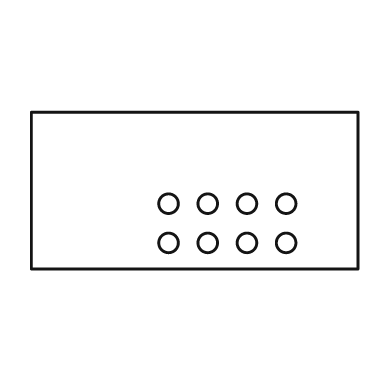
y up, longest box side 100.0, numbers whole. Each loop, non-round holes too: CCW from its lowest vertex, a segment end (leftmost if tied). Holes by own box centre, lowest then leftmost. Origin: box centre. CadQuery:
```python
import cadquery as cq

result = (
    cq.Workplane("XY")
    .moveTo(-50.0, -24.0)
    .lineTo(50.0, -24.0)
    .lineTo(50.0, 24.0)
    .lineTo(-50.0, 24.0)
    .close()
    .moveTo(-8.0, -16.0)
    .circle(3.0)
    .moveTo(4.0, -16.0)
    .circle(3.0)
    .moveTo(16.0, -16.0)
    .circle(3.0)
    .moveTo(28.0, -16.0)
    .circle(3.0)
    .moveTo(-8.0, -4.0)
    .circle(3.0)
    .moveTo(4.0, -4.0)
    .circle(3.0)
    .moveTo(16.0, -4.0)
    .circle(3.0)
    .moveTo(28.0, -4.0)
    .circle(3.0)
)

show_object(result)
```